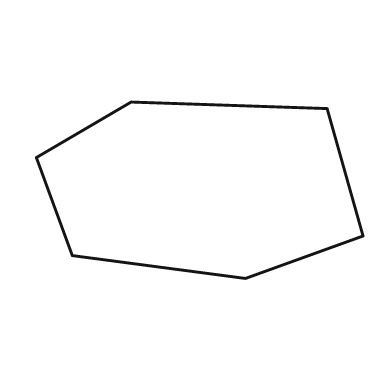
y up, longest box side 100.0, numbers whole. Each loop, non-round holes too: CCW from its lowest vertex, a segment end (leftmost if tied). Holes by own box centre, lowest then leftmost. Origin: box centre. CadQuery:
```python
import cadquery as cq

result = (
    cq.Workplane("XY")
    .moveTo(14.0, -27.0)
    .lineTo(50.0, -14.0)
    .lineTo(39.0, 25.0)
    .lineTo(-21.0, 27.0)
    .lineTo(-50.0, 10.0)
    .lineTo(-39.0, -20.0)
    .close()
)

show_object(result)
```